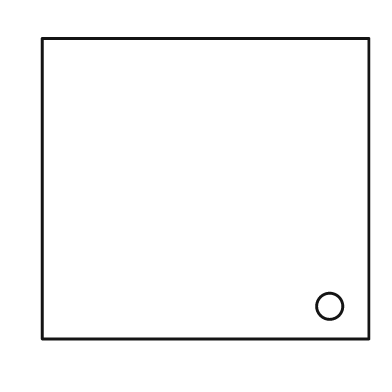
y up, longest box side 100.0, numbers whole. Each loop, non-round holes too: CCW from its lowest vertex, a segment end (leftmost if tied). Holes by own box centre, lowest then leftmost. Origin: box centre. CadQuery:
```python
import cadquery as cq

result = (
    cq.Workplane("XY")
    .moveTo(-50.0, -46.0)
    .lineTo(50.0, -46.0)
    .lineTo(50.0, 46.0)
    .lineTo(-50.0, 46.0)
    .close()
    .moveTo(38.0, -36.0)
    .circle(4.0)
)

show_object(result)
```